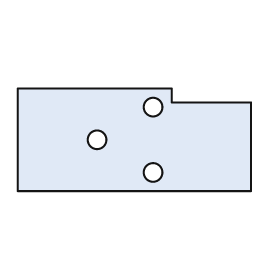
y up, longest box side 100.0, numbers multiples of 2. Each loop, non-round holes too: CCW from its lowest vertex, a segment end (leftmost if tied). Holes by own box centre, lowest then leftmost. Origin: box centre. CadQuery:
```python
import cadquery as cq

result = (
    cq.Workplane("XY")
    .moveTo(-50.0, -22.0)
    .lineTo(50.0, -22.0)
    .lineTo(50.0, 16.0)
    .lineTo(16.0, 16.0)
    .lineTo(16.0, 22.0)
    .lineTo(-50.0, 22.0)
    .close()
    .moveTo(8.0, -14.0)
    .circle(4.0)
    .moveTo(-16.0, 0.0)
    .circle(4.0)
    .moveTo(8.0, 14.0)
    .circle(4.0)
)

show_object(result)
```